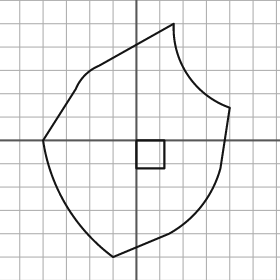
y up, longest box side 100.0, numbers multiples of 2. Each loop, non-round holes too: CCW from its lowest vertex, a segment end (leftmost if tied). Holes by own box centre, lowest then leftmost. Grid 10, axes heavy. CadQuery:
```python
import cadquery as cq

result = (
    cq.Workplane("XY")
    .moveTo(-10.0, -50.0)
    .lineTo(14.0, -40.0)
    .threePointArc((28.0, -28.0), (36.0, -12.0))
    .lineTo(40.0, 14.0)
    .threePointArc((22.0, 28.0), (16.0, 50.0))
    .lineTo(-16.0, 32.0)
    .threePointArc((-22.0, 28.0), (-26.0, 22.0))
    .lineTo(-40.0, 0.0)
    .threePointArc((-30.0, -28.0), (-10.0, -50.0))
    .close()
    .moveTo(0.0, -12.0)
    .lineTo(12.0, -12.0)
    .lineTo(12.0, 0.0)
    .lineTo(0.0, 0.0)
    .close()
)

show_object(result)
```